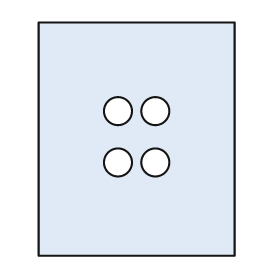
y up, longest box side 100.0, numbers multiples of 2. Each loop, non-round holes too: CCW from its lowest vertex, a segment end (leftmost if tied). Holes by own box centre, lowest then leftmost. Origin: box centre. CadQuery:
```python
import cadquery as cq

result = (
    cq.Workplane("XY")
    .moveTo(-42.0, -50.0)
    .lineTo(42.0, -50.0)
    .lineTo(42.0, 50.0)
    .lineTo(-42.0, 50.0)
    .close()
    .moveTo(-8.0, -10.0)
    .circle(6.0)
    .moveTo(8.0, -10.0)
    .circle(6.0)
    .moveTo(-8.0, 12.0)
    .circle(6.0)
    .moveTo(8.0, 12.0)
    .circle(6.0)
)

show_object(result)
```